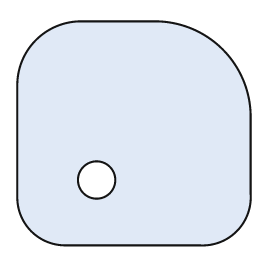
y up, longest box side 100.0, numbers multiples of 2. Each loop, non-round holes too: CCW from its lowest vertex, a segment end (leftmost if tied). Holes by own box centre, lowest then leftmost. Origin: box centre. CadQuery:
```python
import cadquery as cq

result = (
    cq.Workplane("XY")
    .moveTo(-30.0, -48.0)
    .lineTo(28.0, -48.0)
    .threePointArc((44.0, -42.0), (50.0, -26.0))
    .lineTo(50.0, 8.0)
    .threePointArc((38.0, 36.0), (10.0, 48.0))
    .lineTo(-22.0, 48.0)
    .threePointArc((-42.0, 40.0), (-50.0, 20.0))
    .lineTo(-50.0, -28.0)
    .threePointArc((-44.0, -42.0), (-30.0, -48.0))
    .close()
    .moveTo(-16.0, -20.0)
    .circle(8.0)
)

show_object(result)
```